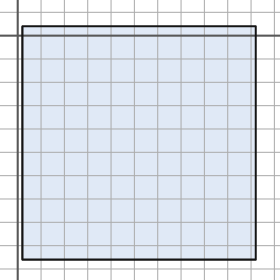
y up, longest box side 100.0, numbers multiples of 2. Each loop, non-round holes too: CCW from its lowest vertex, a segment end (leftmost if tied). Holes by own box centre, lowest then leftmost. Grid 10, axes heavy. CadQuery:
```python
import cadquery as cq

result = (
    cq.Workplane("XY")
    .moveTo(2.0, -96.0)
    .lineTo(102.0, -96.0)
    .lineTo(102.0, 4.0)
    .lineTo(2.0, 4.0)
    .close()
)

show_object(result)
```